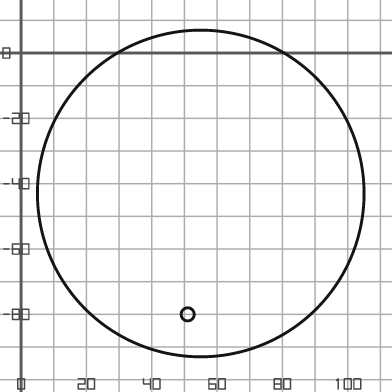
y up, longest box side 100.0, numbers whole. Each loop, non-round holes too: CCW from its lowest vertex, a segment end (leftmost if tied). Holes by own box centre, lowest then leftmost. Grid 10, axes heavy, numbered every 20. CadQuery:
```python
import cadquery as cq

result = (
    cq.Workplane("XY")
    .moveTo(55.0, -43.0)
    .circle(50.0)
    .moveTo(51.0, -80.0)
    .circle(2.0)
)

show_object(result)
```